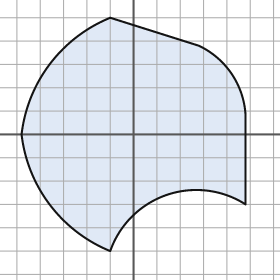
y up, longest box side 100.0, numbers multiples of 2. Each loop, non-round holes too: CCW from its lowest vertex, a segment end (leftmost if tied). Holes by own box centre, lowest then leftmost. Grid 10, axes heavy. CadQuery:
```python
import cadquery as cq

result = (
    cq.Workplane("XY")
    .moveTo(-10.0, -50.0)
    .threePointArc((14.0, -26.0), (48.0, -30.0))
    .lineTo(48.0, 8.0)
    .threePointArc((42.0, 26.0), (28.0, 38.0))
    .lineTo(-10.0, 50.0)
    .threePointArc((-36.0, 30.0), (-48.0, 0.0))
    .threePointArc((-36.0, -30.0), (-10.0, -50.0))
    .close()
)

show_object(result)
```